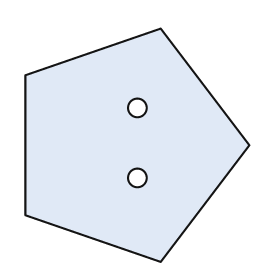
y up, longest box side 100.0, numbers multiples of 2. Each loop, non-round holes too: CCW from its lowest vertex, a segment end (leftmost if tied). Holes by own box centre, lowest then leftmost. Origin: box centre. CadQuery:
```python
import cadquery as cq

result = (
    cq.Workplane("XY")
    .moveTo(10.0, -50.0)
    .lineTo(48.0, 0.0)
    .lineTo(10.0, 50.0)
    .lineTo(-48.0, 30.0)
    .lineTo(-48.0, -30.0)
    .close()
    .moveTo(0.0, -14.0)
    .circle(4.0)
    .moveTo(0.0, 16.0)
    .circle(4.0)
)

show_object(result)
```